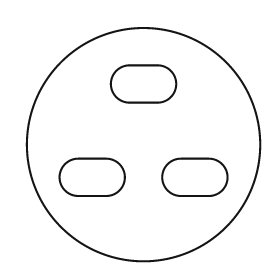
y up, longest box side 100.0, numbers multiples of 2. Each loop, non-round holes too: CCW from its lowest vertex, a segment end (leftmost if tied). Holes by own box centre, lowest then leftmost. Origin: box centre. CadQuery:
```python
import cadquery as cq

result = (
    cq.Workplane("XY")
    .moveTo(0.0, 0.0)
    .circle(50.0)
    .moveTo(-28.0, -22.0)
    .lineTo(-16.0, -22.0)
    .threePointArc((-8.0, -14.0), (-16.0, -6.0))
    .lineTo(-28.0, -6.0)
    .threePointArc((-36.0, -14.0), (-28.0, -22.0))
    .close()
    .moveTo(16.0, -22.0)
    .lineTo(28.0, -22.0)
    .threePointArc((36.0, -14.0), (28.0, -6.0))
    .lineTo(16.0, -6.0)
    .threePointArc((8.0, -14.0), (16.0, -22.0))
    .close()
    .moveTo(-6.0, 18.0)
    .lineTo(6.0, 18.0)
    .threePointArc((14.0, 26.0), (6.0, 34.0))
    .lineTo(-6.0, 34.0)
    .threePointArc((-14.0, 26.0), (-6.0, 18.0))
    .close()
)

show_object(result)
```